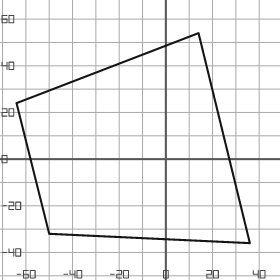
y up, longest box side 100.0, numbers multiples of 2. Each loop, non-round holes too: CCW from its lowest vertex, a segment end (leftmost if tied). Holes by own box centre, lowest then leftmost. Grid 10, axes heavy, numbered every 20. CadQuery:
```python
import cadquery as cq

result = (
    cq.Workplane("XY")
    .moveTo(36.0, -36.0)
    .lineTo(14.0, 54.0)
    .lineTo(-64.0, 24.0)
    .lineTo(-50.0, -32.0)
    .close()
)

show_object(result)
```